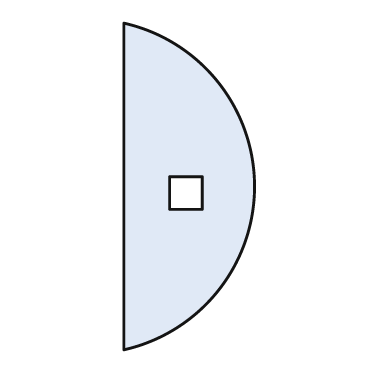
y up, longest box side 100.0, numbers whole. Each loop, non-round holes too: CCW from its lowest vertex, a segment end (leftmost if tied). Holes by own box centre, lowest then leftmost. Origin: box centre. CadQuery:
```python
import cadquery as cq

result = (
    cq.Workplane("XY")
    .moveTo(-20.0, -50.0)
    .threePointArc((20.0, 0.0), (-20.0, 50.0))
    .close()
    .moveTo(-6.0, -7.0)
    .lineTo(4.0, -7.0)
    .lineTo(4.0, 3.0)
    .lineTo(-6.0, 3.0)
    .close()
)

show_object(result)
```